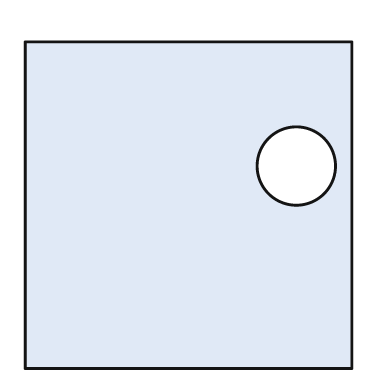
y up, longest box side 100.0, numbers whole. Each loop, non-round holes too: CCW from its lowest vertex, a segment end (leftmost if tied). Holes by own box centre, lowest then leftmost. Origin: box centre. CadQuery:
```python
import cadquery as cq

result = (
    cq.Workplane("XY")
    .moveTo(-50.0, -50.0)
    .lineTo(50.0, -50.0)
    .lineTo(50.0, 50.0)
    .lineTo(-50.0, 50.0)
    .close()
    .moveTo(33.0, 12.0)
    .circle(12.0)
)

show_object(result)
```